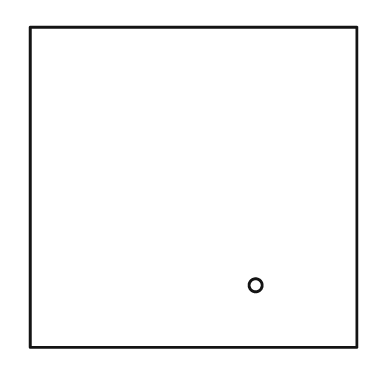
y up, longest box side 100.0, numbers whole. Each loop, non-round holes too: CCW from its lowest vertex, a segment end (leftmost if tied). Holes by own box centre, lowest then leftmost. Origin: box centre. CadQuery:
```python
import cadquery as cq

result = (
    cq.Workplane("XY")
    .moveTo(-50.0, -49.0)
    .lineTo(50.0, -49.0)
    .lineTo(50.0, 49.0)
    .lineTo(-50.0, 49.0)
    .close()
    .moveTo(19.0, -30.0)
    .circle(2.0)
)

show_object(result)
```